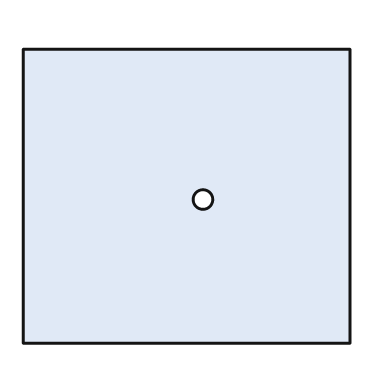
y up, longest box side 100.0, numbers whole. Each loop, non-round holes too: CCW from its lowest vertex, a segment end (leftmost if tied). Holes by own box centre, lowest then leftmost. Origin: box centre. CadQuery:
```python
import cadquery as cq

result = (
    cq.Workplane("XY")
    .moveTo(-50.0, -45.0)
    .lineTo(50.0, -45.0)
    .lineTo(50.0, 45.0)
    .lineTo(-50.0, 45.0)
    .close()
    .moveTo(5.0, -1.0)
    .circle(3.0)
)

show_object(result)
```